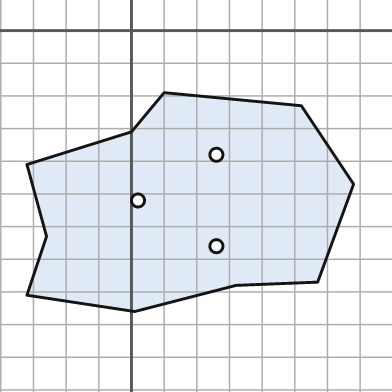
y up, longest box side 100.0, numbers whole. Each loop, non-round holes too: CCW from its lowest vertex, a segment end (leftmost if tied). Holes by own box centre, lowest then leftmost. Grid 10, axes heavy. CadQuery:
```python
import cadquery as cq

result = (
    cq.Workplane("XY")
    .moveTo(1.0, -86.0)
    .lineTo(32.0, -78.0)
    .lineTo(57.0, -77.0)
    .lineTo(68.0, -47.0)
    .lineTo(52.0, -23.0)
    .lineTo(10.0, -19.0)
    .lineTo(0.0, -31.0)
    .lineTo(-32.0, -41.0)
    .lineTo(-26.0, -63.0)
    .lineTo(-32.0, -81.0)
    .close()
    .moveTo(26.0, -66.0)
    .circle(2.0)
    .moveTo(2.0, -52.0)
    .circle(2.0)
    .moveTo(26.0, -38.0)
    .circle(2.0)
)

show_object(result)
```